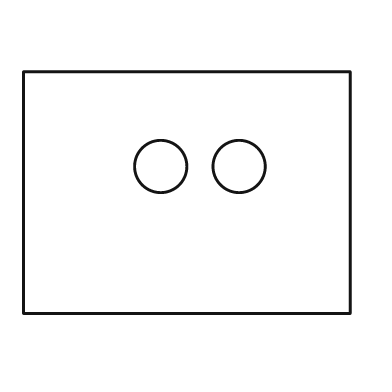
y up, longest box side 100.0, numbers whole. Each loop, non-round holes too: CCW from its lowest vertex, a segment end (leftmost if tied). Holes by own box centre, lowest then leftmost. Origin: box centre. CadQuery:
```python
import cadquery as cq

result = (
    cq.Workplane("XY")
    .moveTo(-50.0, -37.0)
    .lineTo(50.0, -37.0)
    .lineTo(50.0, 37.0)
    .lineTo(-50.0, 37.0)
    .close()
    .moveTo(-8.0, 8.0)
    .circle(8.0)
    .moveTo(16.0, 8.0)
    .circle(8.0)
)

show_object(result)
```